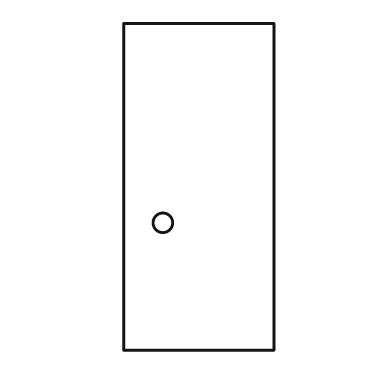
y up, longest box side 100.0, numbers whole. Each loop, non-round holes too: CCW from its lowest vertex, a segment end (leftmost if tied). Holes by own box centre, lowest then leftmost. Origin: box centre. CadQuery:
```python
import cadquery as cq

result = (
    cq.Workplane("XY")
    .moveTo(-23.0, -50.0)
    .lineTo(23.0, -50.0)
    .lineTo(23.0, 50.0)
    .lineTo(-23.0, 50.0)
    .close()
    .moveTo(-11.0, -11.0)
    .circle(3.0)
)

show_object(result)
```